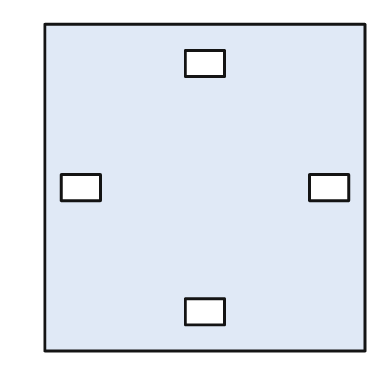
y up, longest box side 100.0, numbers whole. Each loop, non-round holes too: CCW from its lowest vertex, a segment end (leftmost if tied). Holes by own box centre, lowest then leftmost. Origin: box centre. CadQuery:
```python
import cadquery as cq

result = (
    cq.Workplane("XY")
    .moveTo(-49.0, -50.0)
    .lineTo(49.0, -50.0)
    .lineTo(49.0, 50.0)
    .lineTo(-49.0, 50.0)
    .close()
    .moveTo(-6.0, -42.0)
    .lineTo(6.0, -42.0)
    .lineTo(6.0, -34.0)
    .lineTo(-6.0, -34.0)
    .close()
    .moveTo(-44.0, -4.0)
    .lineTo(-32.0, -4.0)
    .lineTo(-32.0, 4.0)
    .lineTo(-44.0, 4.0)
    .close()
    .moveTo(32.0, -4.0)
    .lineTo(44.0, -4.0)
    .lineTo(44.0, 4.0)
    .lineTo(32.0, 4.0)
    .close()
    .moveTo(-6.0, 34.0)
    .lineTo(6.0, 34.0)
    .lineTo(6.0, 42.0)
    .lineTo(-6.0, 42.0)
    .close()
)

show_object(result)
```